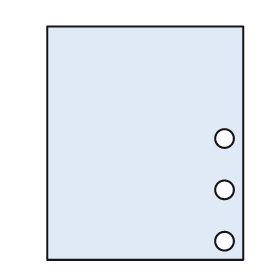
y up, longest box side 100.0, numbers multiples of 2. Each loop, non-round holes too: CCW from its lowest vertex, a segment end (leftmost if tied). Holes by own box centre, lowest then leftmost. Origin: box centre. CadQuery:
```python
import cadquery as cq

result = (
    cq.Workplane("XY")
    .moveTo(-42.0, -50.0)
    .lineTo(42.0, -50.0)
    .lineTo(42.0, 50.0)
    .lineTo(-42.0, 50.0)
    .close()
    .moveTo(34.0, -42.0)
    .circle(4.0)
    .moveTo(34.0, -20.0)
    .circle(4.0)
    .moveTo(34.0, 2.0)
    .circle(4.0)
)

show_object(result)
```